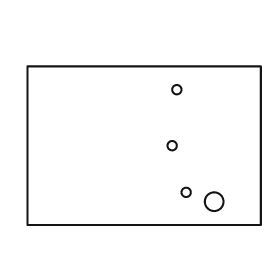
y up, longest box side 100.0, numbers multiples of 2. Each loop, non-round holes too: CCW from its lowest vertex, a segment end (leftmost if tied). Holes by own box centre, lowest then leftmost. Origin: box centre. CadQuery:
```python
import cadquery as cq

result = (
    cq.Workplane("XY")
    .moveTo(-50.0, -34.0)
    .lineTo(50.0, -34.0)
    .lineTo(50.0, 34.0)
    .lineTo(-50.0, 34.0)
    .close()
    .moveTo(30.0, -24.0)
    .circle(4.0)
    .moveTo(18.0, -20.0)
    .circle(2.0)
    .moveTo(12.0, 0.0)
    .circle(2.0)
    .moveTo(14.0, 24.0)
    .circle(2.0)
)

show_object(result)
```